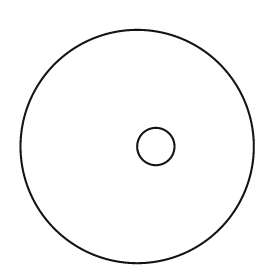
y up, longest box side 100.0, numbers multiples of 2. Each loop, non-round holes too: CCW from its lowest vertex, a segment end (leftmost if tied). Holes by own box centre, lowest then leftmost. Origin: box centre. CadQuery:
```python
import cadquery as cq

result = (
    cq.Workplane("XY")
    .moveTo(0.0, 0.0)
    .circle(50.0)
    .moveTo(8.0, 0.0)
    .circle(8.0)
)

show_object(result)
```